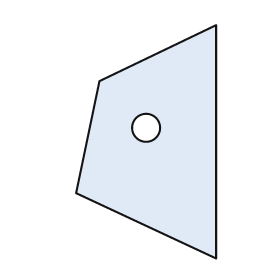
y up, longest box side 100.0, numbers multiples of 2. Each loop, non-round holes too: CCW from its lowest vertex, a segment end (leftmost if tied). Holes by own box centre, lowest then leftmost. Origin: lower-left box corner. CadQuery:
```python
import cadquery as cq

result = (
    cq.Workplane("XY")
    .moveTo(60.0, 0.0)
    .lineTo(60.0, 100.0)
    .lineTo(10.0, 76.0)
    .lineTo(0.0, 28.0)
    .close()
    .moveTo(30.0, 56.0)
    .circle(6.0)
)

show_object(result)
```